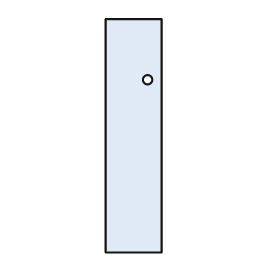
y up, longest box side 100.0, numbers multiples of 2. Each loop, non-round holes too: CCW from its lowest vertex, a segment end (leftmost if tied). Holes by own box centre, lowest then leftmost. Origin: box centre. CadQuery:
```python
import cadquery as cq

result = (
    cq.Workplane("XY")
    .moveTo(-12.0, -50.0)
    .lineTo(12.0, -50.0)
    .lineTo(12.0, 50.0)
    .lineTo(-12.0, 50.0)
    .close()
    .moveTo(6.0, 24.0)
    .circle(2.0)
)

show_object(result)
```